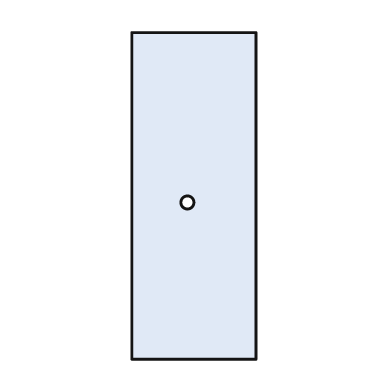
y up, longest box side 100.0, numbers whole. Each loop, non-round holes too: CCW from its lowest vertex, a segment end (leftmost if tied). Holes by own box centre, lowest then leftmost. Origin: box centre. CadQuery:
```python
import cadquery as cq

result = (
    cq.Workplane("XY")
    .moveTo(-19.0, -50.0)
    .lineTo(19.0, -50.0)
    .lineTo(19.0, 50.0)
    .lineTo(-19.0, 50.0)
    .close()
    .moveTo(-2.0, -2.0)
    .circle(2.0)
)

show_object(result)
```